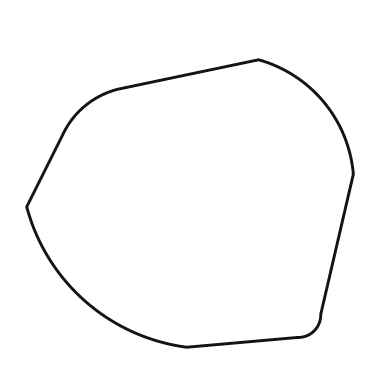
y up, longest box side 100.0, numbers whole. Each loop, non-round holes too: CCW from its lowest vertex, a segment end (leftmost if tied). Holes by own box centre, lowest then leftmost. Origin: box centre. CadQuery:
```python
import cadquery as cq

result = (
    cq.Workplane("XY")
    .moveTo(-1.0, -44.0)
    .lineTo(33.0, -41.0)
    .threePointArc((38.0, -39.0), (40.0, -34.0))
    .lineTo(50.0, 9.0)
    .threePointArc((41.0, 31.0), (21.0, 44.0))
    .lineTo(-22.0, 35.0)
    .threePointArc((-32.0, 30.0), (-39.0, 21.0))
    .lineTo(-50.0, -1.0)
    .threePointArc((-32.0, -30.0), (-1.0, -44.0))
    .close()
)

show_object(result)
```